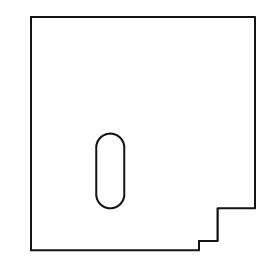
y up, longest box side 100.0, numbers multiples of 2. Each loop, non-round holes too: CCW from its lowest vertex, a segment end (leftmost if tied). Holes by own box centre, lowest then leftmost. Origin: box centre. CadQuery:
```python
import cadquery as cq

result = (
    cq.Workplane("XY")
    .moveTo(-48.0, -50.0)
    .lineTo(24.0, -50.0)
    .lineTo(24.0, -46.0)
    .lineTo(32.0, -46.0)
    .lineTo(32.0, -32.0)
    .lineTo(48.0, -32.0)
    .lineTo(48.0, 50.0)
    .lineTo(-48.0, 50.0)
    .close()
    .moveTo(-20.0, -26.0)
    .threePointArc((-14.0, -32.0), (-8.0, -26.0))
    .lineTo(-8.0, -6.0)
    .threePointArc((-14.0, 0.0), (-20.0, -6.0))
    .close()
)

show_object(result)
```